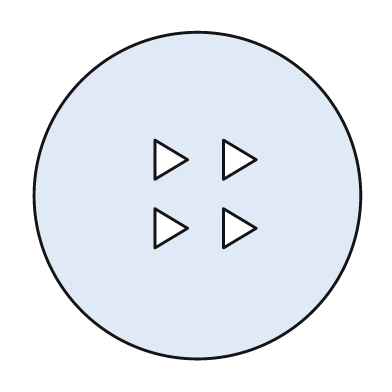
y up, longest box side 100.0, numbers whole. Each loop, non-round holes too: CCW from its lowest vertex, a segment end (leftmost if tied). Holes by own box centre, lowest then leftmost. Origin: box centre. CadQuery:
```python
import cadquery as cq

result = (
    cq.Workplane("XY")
    .moveTo(0.0, 0.0)
    .circle(50.0)
    .moveTo(-13.0, -16.0)
    .lineTo(-3.0, -10.0)
    .lineTo(-13.0, -4.0)
    .close()
    .moveTo(8.0, -16.0)
    .lineTo(18.0, -10.0)
    .lineTo(8.0, -4.0)
    .close()
    .moveTo(-13.0, 5.0)
    .lineTo(-3.0, 11.0)
    .lineTo(-13.0, 17.0)
    .close()
    .moveTo(8.0, 5.0)
    .lineTo(18.0, 11.0)
    .lineTo(8.0, 17.0)
    .close()
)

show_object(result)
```